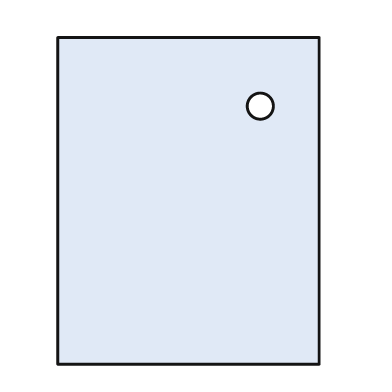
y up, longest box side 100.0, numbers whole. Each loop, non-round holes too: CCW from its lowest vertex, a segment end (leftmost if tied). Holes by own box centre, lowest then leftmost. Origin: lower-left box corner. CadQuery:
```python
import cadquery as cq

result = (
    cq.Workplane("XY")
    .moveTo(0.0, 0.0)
    .lineTo(80.0, 0.0)
    .lineTo(80.0, 100.0)
    .lineTo(0.0, 100.0)
    .close()
    .moveTo(62.0, 79.0)
    .circle(4.0)
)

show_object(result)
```